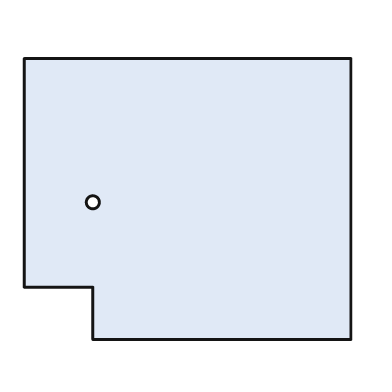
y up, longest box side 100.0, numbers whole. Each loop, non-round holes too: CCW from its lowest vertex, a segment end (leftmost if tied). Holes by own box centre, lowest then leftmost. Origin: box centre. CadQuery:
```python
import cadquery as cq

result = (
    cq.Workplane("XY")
    .moveTo(-29.0, -43.0)
    .lineTo(50.0, -43.0)
    .lineTo(50.0, 43.0)
    .lineTo(-50.0, 43.0)
    .lineTo(-50.0, -27.0)
    .lineTo(-29.0, -27.0)
    .close()
    .moveTo(-29.0, -1.0)
    .circle(2.0)
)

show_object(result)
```